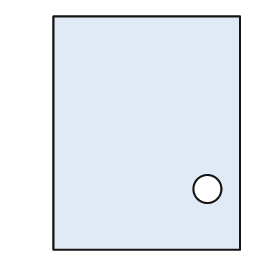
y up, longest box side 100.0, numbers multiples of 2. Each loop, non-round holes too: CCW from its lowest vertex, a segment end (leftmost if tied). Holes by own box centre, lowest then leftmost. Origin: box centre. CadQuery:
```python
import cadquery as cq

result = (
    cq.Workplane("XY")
    .moveTo(-40.0, -50.0)
    .lineTo(40.0, -50.0)
    .lineTo(40.0, 50.0)
    .lineTo(-40.0, 50.0)
    .close()
    .moveTo(26.0, -24.0)
    .circle(6.0)
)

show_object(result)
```